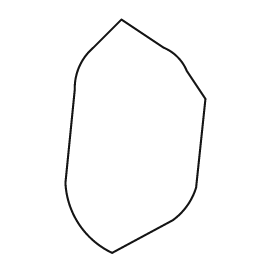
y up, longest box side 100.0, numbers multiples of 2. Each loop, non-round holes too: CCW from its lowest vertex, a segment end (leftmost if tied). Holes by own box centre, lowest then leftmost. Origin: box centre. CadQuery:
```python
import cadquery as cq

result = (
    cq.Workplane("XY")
    .moveTo(-10.0, -50.0)
    .lineTo(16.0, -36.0)
    .threePointArc((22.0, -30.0), (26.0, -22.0))
    .lineTo(30.0, 16.0)
    .lineTo(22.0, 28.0)
    .threePointArc((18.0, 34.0), (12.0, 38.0))
    .lineTo(-6.0, 50.0)
    .lineTo(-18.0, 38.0)
    .threePointArc((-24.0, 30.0), (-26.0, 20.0))
    .lineTo(-30.0, -20.0)
    .threePointArc((-24.0, -38.0), (-10.0, -50.0))
    .close()
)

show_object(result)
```